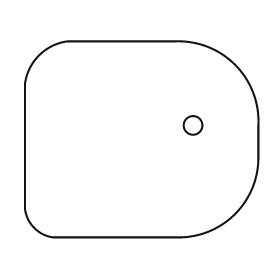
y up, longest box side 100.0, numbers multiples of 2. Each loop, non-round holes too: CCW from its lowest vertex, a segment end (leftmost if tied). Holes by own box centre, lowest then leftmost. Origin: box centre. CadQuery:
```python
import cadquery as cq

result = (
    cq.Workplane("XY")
    .moveTo(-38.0, -42.0)
    .lineTo(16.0, -42.0)
    .threePointArc((40.0, -32.0), (50.0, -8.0))
    .lineTo(50.0, 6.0)
    .threePointArc((40.0, 32.0), (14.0, 42.0))
    .lineTo(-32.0, 42.0)
    .threePointArc((-44.0, 36.0), (-50.0, 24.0))
    .lineTo(-50.0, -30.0)
    .threePointArc((-46.0, -38.0), (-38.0, -42.0))
    .close()
    .moveTo(22.0, 6.0)
    .circle(4.0)
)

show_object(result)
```